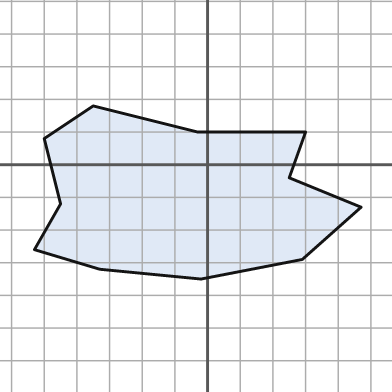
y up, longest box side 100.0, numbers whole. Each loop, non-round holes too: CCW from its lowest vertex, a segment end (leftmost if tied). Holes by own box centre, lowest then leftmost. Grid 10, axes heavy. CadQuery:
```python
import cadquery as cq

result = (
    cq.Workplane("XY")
    .moveTo(-2.0, -35.0)
    .lineTo(29.0, -29.0)
    .lineTo(47.0, -13.0)
    .lineTo(25.0, -4.0)
    .lineTo(30.0, 10.0)
    .lineTo(-3.0, 10.0)
    .lineTo(-35.0, 18.0)
    .lineTo(-50.0, 8.0)
    .lineTo(-45.0, -12.0)
    .lineTo(-53.0, -26.0)
    .lineTo(-33.0, -32.0)
    .close()
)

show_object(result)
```